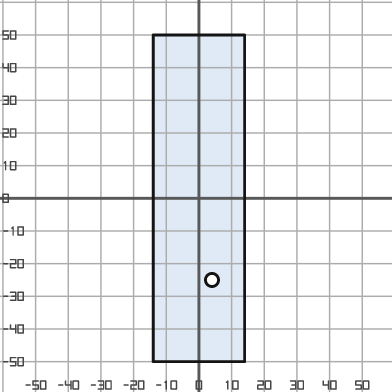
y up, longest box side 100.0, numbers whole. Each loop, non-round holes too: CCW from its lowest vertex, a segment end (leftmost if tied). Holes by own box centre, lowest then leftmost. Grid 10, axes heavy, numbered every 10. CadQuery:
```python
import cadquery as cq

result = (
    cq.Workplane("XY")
    .moveTo(-14.0, -50.0)
    .lineTo(14.0, -50.0)
    .lineTo(14.0, 50.0)
    .lineTo(-14.0, 50.0)
    .close()
    .moveTo(4.0, -25.0)
    .circle(2.0)
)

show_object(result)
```